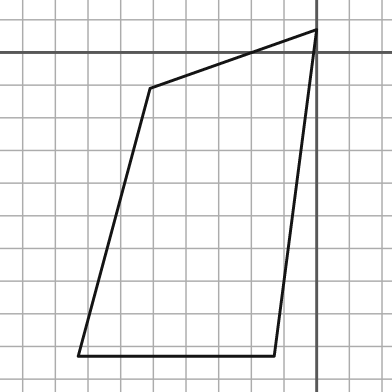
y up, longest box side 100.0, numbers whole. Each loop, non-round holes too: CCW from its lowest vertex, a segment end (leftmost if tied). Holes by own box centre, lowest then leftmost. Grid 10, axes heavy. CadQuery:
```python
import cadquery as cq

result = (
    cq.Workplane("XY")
    .moveTo(-73.0, -93.0)
    .lineTo(-13.0, -93.0)
    .lineTo(0.0, 7.0)
    .lineTo(-51.0, -11.0)
    .close()
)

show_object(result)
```